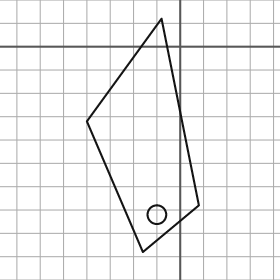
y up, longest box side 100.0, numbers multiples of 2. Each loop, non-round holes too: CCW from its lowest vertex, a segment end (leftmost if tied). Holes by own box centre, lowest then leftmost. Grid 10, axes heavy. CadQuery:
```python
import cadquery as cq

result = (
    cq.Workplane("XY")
    .moveTo(-16.0, -88.0)
    .lineTo(8.0, -68.0)
    .lineTo(-8.0, 12.0)
    .lineTo(-40.0, -32.0)
    .close()
    .moveTo(-10.0, -72.0)
    .circle(4.0)
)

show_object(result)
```